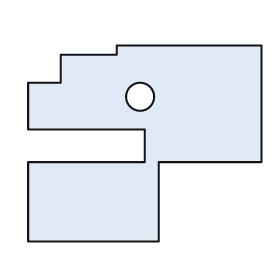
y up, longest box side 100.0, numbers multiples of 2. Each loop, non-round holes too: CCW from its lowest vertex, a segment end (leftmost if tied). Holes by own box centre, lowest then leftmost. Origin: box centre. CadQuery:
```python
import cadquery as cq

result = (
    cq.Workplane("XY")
    .moveTo(-50.0, -42.0)
    .lineTo(6.0, -42.0)
    .lineTo(6.0, -8.0)
    .lineTo(50.0, -8.0)
    .lineTo(50.0, 42.0)
    .lineTo(-12.0, 42.0)
    .lineTo(-12.0, 38.0)
    .lineTo(-36.0, 38.0)
    .lineTo(-36.0, 26.0)
    .lineTo(-50.0, 26.0)
    .lineTo(-50.0, 6.0)
    .lineTo(0.0, 6.0)
    .lineTo(0.0, -8.0)
    .lineTo(-50.0, -8.0)
    .close()
    .moveTo(-2.0, 20.0)
    .circle(6.0)
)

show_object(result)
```